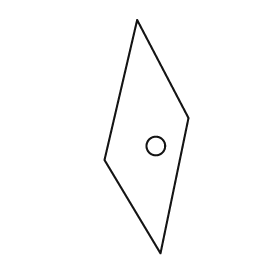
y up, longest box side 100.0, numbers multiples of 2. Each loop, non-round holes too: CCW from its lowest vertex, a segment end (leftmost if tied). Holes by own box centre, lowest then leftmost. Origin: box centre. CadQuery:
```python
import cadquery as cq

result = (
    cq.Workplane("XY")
    .moveTo(6.0, -50.0)
    .lineTo(18.0, 8.0)
    .lineTo(-4.0, 50.0)
    .lineTo(-18.0, -10.0)
    .close()
    .moveTo(4.0, -4.0)
    .circle(4.0)
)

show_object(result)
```